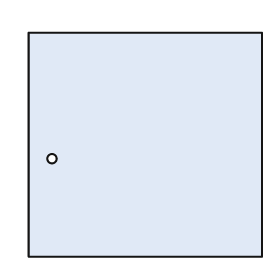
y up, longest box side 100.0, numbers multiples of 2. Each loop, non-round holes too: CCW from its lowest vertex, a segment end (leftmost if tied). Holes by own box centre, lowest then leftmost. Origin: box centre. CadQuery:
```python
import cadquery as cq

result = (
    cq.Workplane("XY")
    .moveTo(-50.0, -48.0)
    .lineTo(50.0, -48.0)
    .lineTo(50.0, 48.0)
    .lineTo(-50.0, 48.0)
    .close()
    .moveTo(-40.0, -6.0)
    .circle(2.0)
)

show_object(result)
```